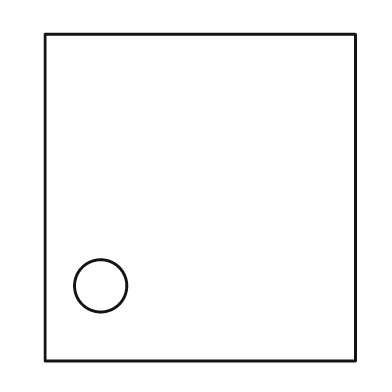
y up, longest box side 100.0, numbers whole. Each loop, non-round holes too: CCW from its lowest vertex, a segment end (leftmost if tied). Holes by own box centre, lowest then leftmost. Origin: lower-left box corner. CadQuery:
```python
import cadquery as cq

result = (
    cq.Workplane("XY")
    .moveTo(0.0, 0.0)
    .lineTo(95.0, 0.0)
    .lineTo(95.0, 100.0)
    .lineTo(0.0, 100.0)
    .close()
    .moveTo(17.0, 23.0)
    .circle(8.0)
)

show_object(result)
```